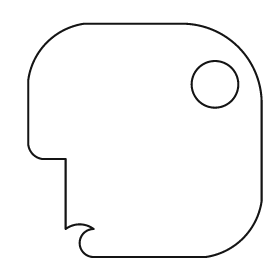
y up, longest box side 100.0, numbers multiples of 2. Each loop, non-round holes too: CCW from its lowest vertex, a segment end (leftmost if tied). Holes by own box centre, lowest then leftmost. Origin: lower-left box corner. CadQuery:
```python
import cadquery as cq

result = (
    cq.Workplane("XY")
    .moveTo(28.0, 0.0)
    .lineTo(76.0, 0.0)
    .threePointArc((92.0, 8.0), (100.0, 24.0))
    .lineTo(100.0, 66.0)
    .threePointArc((90.0, 90.0), (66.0, 100.0))
    .lineTo(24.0, 100.0)
    .threePointArc((8.0, 92.0), (0.0, 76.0))
    .lineTo(0.0, 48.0)
    .threePointArc((2.0, 44.0), (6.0, 42.0))
    .lineTo(16.0, 42.0)
    .lineTo(16.0, 12.0)
    .threePointArc((22.0, 14.0), (28.0, 12.0))
    .threePointArc((22.0, 6.0), (28.0, 0.0))
    .close()
    .moveTo(80.0, 74.0)
    .circle(10.0)
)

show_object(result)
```